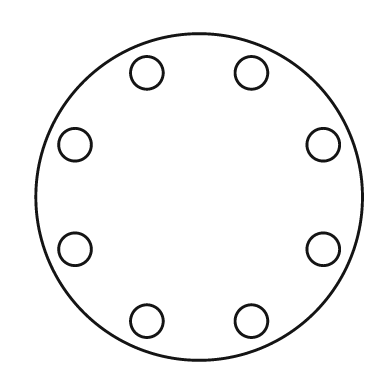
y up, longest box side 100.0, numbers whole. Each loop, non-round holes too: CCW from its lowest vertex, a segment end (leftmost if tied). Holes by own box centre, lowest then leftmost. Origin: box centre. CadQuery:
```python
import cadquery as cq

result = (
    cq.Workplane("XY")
    .moveTo(0.0, 0.0)
    .circle(50.0)
    .moveTo(-16.0, -38.0)
    .circle(5.0)
    .moveTo(16.0, -38.0)
    .circle(5.0)
    .moveTo(-38.0, -16.0)
    .circle(5.0)
    .moveTo(38.0, -16.0)
    .circle(5.0)
    .moveTo(-38.0, 16.0)
    .circle(5.0)
    .moveTo(38.0, 16.0)
    .circle(5.0)
    .moveTo(-16.0, 38.0)
    .circle(5.0)
    .moveTo(16.0, 38.0)
    .circle(5.0)
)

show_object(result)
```